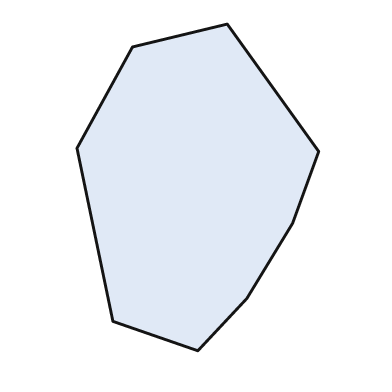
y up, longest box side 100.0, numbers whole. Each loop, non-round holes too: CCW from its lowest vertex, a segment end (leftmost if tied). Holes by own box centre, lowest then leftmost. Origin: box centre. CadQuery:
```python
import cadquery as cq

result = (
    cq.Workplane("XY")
    .moveTo(0.0, -50.0)
    .lineTo(15.0, -34.0)
    .lineTo(29.0, -11.0)
    .lineTo(37.0, 11.0)
    .lineTo(9.0, 50.0)
    .lineTo(-20.0, 43.0)
    .lineTo(-37.0, 12.0)
    .lineTo(-26.0, -41.0)
    .close()
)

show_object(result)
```